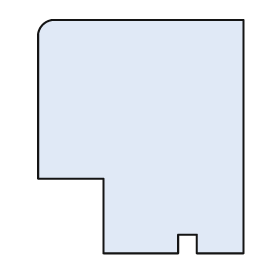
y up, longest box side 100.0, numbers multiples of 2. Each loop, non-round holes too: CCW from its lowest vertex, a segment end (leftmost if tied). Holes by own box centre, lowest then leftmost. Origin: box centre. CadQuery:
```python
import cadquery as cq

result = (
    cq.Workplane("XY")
    .moveTo(-16.0, -50.0)
    .lineTo(16.0, -50.0)
    .lineTo(16.0, -42.0)
    .lineTo(24.0, -42.0)
    .lineTo(24.0, -50.0)
    .lineTo(44.0, -50.0)
    .lineTo(44.0, 50.0)
    .lineTo(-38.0, 50.0)
    .threePointArc((-42.0, 48.0), (-44.0, 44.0))
    .lineTo(-44.0, -18.0)
    .lineTo(-16.0, -18.0)
    .close()
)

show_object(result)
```